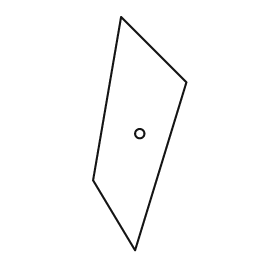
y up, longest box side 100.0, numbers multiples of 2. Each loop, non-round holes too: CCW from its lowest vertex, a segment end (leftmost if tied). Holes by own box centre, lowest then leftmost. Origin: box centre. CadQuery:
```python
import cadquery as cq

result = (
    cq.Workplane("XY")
    .moveTo(-2.0, -50.0)
    .lineTo(20.0, 22.0)
    .lineTo(-8.0, 50.0)
    .lineTo(-20.0, -20.0)
    .close()
    .moveTo(0.0, 0.0)
    .circle(2.0)
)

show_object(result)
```